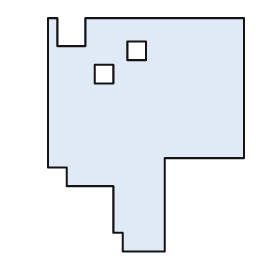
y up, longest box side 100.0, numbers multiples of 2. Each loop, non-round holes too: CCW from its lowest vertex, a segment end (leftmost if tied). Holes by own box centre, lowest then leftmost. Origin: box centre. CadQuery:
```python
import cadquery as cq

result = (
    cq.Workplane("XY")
    .moveTo(-10.0, -50.0)
    .lineTo(8.0, -50.0)
    .lineTo(8.0, -10.0)
    .lineTo(42.0, -10.0)
    .lineTo(42.0, 50.0)
    .lineTo(-26.0, 50.0)
    .lineTo(-26.0, 38.0)
    .lineTo(-38.0, 38.0)
    .lineTo(-38.0, 50.0)
    .lineTo(-42.0, 50.0)
    .lineTo(-42.0, -14.0)
    .lineTo(-34.0, -14.0)
    .lineTo(-34.0, -22.0)
    .lineTo(-14.0, -22.0)
    .lineTo(-14.0, -42.0)
    .lineTo(-10.0, -42.0)
    .close()
    .moveTo(-22.0, 22.0)
    .lineTo(-14.0, 22.0)
    .lineTo(-14.0, 30.0)
    .lineTo(-22.0, 30.0)
    .close()
    .moveTo(-8.0, 32.0)
    .lineTo(0.0, 32.0)
    .lineTo(0.0, 40.0)
    .lineTo(-8.0, 40.0)
    .close()
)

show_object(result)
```